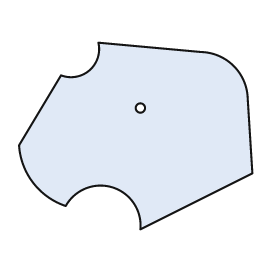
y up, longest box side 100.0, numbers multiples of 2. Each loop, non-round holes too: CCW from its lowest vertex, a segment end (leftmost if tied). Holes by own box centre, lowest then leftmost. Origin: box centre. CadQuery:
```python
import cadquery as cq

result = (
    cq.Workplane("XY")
    .moveTo(2.0, -40.0)
    .lineTo(50.0, -16.0)
    .lineTo(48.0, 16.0)
    .threePointArc((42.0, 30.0), (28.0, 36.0))
    .lineTo(-16.0, 40.0)
    .threePointArc((-20.0, 28.0), (-32.0, 26.0))
    .lineTo(-50.0, -4.0)
    .threePointArc((-44.0, -20.0), (-30.0, -30.0))
    .threePointArc((-10.0, -22.0), (2.0, -40.0))
    .close()
    .moveTo(2.0, 12.0)
    .circle(2.0)
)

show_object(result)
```